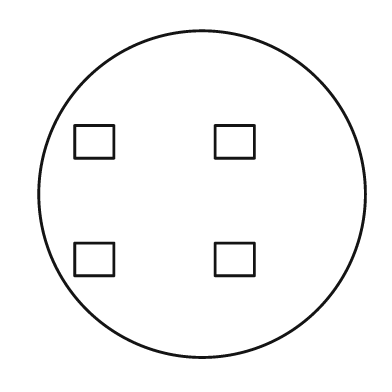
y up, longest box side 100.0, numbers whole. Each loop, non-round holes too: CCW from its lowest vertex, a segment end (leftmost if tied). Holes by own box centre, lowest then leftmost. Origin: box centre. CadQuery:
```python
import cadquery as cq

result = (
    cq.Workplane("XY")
    .moveTo(0.0, 0.0)
    .circle(50.0)
    .moveTo(-39.0, -25.0)
    .lineTo(-27.0, -25.0)
    .lineTo(-27.0, -15.0)
    .lineTo(-39.0, -15.0)
    .close()
    .moveTo(4.0, -25.0)
    .lineTo(16.0, -25.0)
    .lineTo(16.0, -15.0)
    .lineTo(4.0, -15.0)
    .close()
    .moveTo(-39.0, 11.0)
    .lineTo(-27.0, 11.0)
    .lineTo(-27.0, 21.0)
    .lineTo(-39.0, 21.0)
    .close()
    .moveTo(4.0, 11.0)
    .lineTo(16.0, 11.0)
    .lineTo(16.0, 21.0)
    .lineTo(4.0, 21.0)
    .close()
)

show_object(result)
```